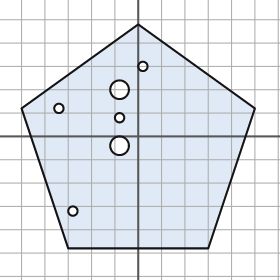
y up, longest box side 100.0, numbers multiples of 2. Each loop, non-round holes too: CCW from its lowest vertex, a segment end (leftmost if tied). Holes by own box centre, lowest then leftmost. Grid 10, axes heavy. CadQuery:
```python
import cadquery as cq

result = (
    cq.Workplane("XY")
    .moveTo(-30.0, -48.0)
    .lineTo(30.0, -48.0)
    .lineTo(50.0, 12.0)
    .lineTo(0.0, 48.0)
    .lineTo(-50.0, 12.0)
    .close()
    .moveTo(-28.0, -32.0)
    .circle(2.0)
    .moveTo(-8.0, -4.0)
    .circle(4.0)
    .moveTo(-8.0, 8.0)
    .circle(2.0)
    .moveTo(-34.0, 12.0)
    .circle(2.0)
    .moveTo(-8.0, 20.0)
    .circle(4.0)
    .moveTo(2.0, 30.0)
    .circle(2.0)
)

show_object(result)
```